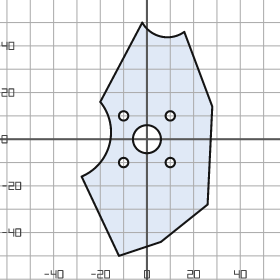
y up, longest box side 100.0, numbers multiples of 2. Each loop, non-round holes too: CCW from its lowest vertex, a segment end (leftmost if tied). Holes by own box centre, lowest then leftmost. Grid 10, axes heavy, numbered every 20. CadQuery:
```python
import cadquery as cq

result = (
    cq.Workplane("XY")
    .moveTo(-12.0, -50.0)
    .lineTo(6.0, -44.0)
    .lineTo(26.0, -28.0)
    .lineTo(28.0, 14.0)
    .lineTo(16.0, 46.0)
    .threePointArc((6.0, 44.0), (-2.0, 50.0))
    .lineTo(-20.0, 16.0)
    .threePointArc((-16.0, -2.0), (-28.0, -16.0))
    .close()
    .moveTo(-10.0, -10.0)
    .circle(2.0)
    .moveTo(10.0, -10.0)
    .circle(2.0)
    .moveTo(0.0, 0.0)
    .circle(6.0)
    .moveTo(-10.0, 10.0)
    .circle(2.0)
    .moveTo(10.0, 10.0)
    .circle(2.0)
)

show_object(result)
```